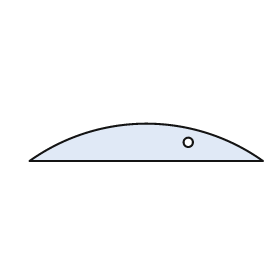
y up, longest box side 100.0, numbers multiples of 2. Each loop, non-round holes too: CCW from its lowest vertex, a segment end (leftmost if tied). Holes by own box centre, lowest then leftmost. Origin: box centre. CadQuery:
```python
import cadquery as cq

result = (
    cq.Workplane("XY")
    .moveTo(-50.0, -8.0)
    .lineTo(50.0, -8.0)
    .threePointArc((0.0, 8.0), (-50.0, -8.0))
    .close()
    .moveTo(18.0, 0.0)
    .circle(2.0)
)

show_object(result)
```